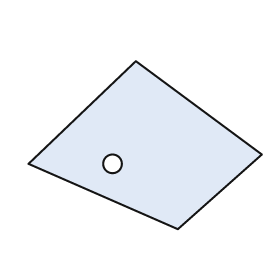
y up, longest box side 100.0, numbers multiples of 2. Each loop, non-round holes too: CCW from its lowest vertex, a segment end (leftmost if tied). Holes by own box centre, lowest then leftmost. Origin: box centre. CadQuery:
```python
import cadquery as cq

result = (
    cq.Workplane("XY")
    .moveTo(14.0, -36.0)
    .lineTo(50.0, -4.0)
    .lineTo(-4.0, 36.0)
    .lineTo(-50.0, -8.0)
    .close()
    .moveTo(-14.0, -8.0)
    .circle(4.0)
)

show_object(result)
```